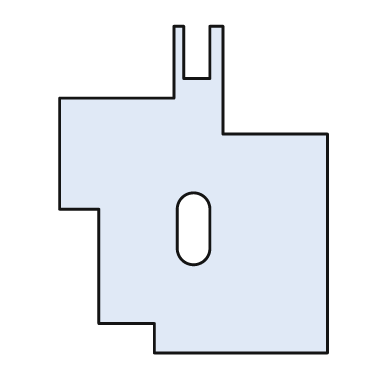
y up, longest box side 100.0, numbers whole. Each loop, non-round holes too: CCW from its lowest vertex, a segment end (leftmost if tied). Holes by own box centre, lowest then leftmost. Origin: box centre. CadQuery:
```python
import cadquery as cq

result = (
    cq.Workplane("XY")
    .moveTo(-12.0, -50.0)
    .lineTo(41.0, -50.0)
    .lineTo(41.0, 17.0)
    .lineTo(9.0, 17.0)
    .lineTo(9.0, 50.0)
    .lineTo(5.0, 50.0)
    .lineTo(5.0, 34.0)
    .lineTo(-3.0, 34.0)
    .lineTo(-3.0, 50.0)
    .lineTo(-6.0, 50.0)
    .lineTo(-6.0, 28.0)
    .lineTo(-41.0, 28.0)
    .lineTo(-41.0, -6.0)
    .lineTo(-29.0, -6.0)
    .lineTo(-29.0, -41.0)
    .lineTo(-12.0, -41.0)
    .close()
    .moveTo(-5.0, -18.0)
    .threePointArc((0.0, -23.0), (5.0, -18.0))
    .lineTo(5.0, -6.0)
    .threePointArc((0.0, -1.0), (-5.0, -6.0))
    .close()
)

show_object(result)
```